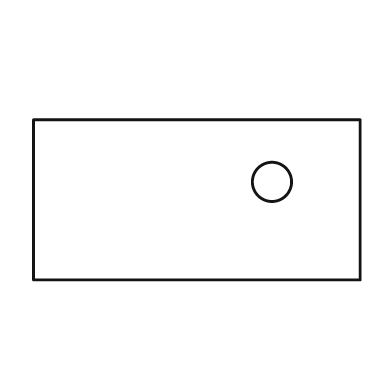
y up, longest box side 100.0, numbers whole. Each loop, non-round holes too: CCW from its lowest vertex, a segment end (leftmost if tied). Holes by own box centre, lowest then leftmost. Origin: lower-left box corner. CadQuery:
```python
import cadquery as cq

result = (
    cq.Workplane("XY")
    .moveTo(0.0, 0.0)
    .lineTo(100.0, 0.0)
    .lineTo(100.0, 49.0)
    .lineTo(0.0, 49.0)
    .close()
    .moveTo(73.0, 30.0)
    .circle(6.0)
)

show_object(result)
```